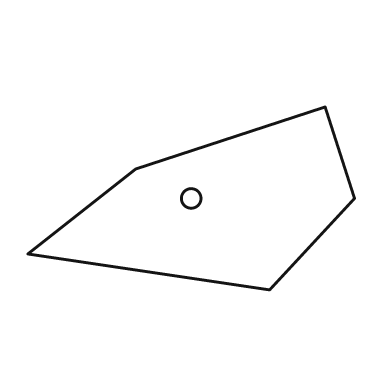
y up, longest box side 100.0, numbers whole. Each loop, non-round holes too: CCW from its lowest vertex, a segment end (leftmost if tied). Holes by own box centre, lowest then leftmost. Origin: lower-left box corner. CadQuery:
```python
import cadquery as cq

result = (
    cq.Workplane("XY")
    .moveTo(74.0, 0.0)
    .lineTo(100.0, 28.0)
    .lineTo(91.0, 56.0)
    .lineTo(33.0, 37.0)
    .lineTo(0.0, 11.0)
    .close()
    .moveTo(50.0, 28.0)
    .circle(3.0)
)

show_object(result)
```